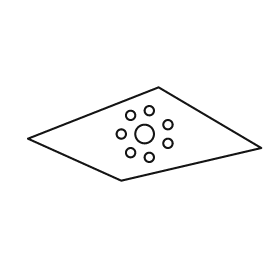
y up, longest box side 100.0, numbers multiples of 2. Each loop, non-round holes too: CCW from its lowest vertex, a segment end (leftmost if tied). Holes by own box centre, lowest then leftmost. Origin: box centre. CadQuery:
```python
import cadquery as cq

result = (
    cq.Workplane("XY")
    .moveTo(-10.0, -20.0)
    .lineTo(50.0, -6.0)
    .lineTo(6.0, 20.0)
    .lineTo(-50.0, -2.0)
    .close()
    .moveTo(2.0, -10.0)
    .circle(2.0)
    .moveTo(-6.0, -8.0)
    .circle(2.0)
    .moveTo(10.0, -4.0)
    .circle(2.0)
    .moveTo(-10.0, 0.0)
    .circle(2.0)
    .moveTo(0.0, 0.0)
    .circle(4.0)
    .moveTo(10.0, 4.0)
    .circle(2.0)
    .moveTo(-6.0, 8.0)
    .circle(2.0)
    .moveTo(2.0, 10.0)
    .circle(2.0)
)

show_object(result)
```